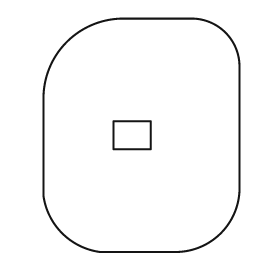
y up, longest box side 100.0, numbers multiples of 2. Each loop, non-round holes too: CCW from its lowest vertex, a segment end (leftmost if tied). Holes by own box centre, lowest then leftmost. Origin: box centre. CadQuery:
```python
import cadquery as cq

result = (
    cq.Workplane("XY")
    .moveTo(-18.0, -50.0)
    .lineTo(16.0, -50.0)
    .threePointArc((34.0, -42.0), (42.0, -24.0))
    .lineTo(42.0, 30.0)
    .threePointArc((36.0, 44.0), (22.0, 50.0))
    .lineTo(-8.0, 50.0)
    .threePointArc((-32.0, 40.0), (-42.0, 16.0))
    .lineTo(-42.0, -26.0)
    .threePointArc((-34.0, -42.0), (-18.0, -50.0))
    .close()
    .moveTo(-12.0, -6.0)
    .lineTo(4.0, -6.0)
    .lineTo(4.0, 6.0)
    .lineTo(-12.0, 6.0)
    .close()
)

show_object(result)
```